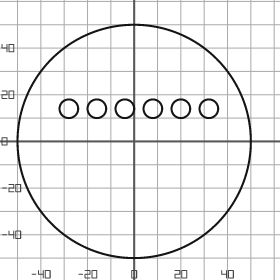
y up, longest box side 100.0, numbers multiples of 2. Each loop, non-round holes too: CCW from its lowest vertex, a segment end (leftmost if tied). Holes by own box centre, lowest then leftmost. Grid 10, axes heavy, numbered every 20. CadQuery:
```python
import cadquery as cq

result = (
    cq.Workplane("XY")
    .moveTo(0.0, 0.0)
    .circle(50.0)
    .moveTo(-28.0, 14.0)
    .circle(4.0)
    .moveTo(-16.0, 14.0)
    .circle(4.0)
    .moveTo(-4.0, 14.0)
    .circle(4.0)
    .moveTo(8.0, 14.0)
    .circle(4.0)
    .moveTo(20.0, 14.0)
    .circle(4.0)
    .moveTo(32.0, 14.0)
    .circle(4.0)
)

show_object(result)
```